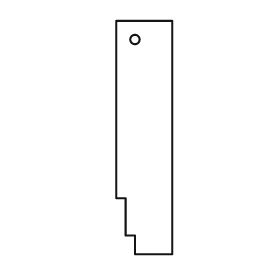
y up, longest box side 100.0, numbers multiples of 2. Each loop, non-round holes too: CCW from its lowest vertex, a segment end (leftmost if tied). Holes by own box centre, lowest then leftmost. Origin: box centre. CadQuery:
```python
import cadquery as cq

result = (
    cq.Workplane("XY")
    .moveTo(-4.0, -50.0)
    .lineTo(12.0, -50.0)
    .lineTo(12.0, 50.0)
    .lineTo(-12.0, 50.0)
    .lineTo(-12.0, -26.0)
    .lineTo(-8.0, -26.0)
    .lineTo(-8.0, -42.0)
    .lineTo(-4.0, -42.0)
    .close()
    .moveTo(-4.0, 42.0)
    .circle(2.0)
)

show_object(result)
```